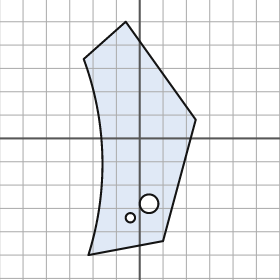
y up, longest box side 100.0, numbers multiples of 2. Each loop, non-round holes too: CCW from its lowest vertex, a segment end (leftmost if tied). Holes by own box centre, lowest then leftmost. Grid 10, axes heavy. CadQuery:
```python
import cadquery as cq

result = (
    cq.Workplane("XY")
    .moveTo(-22.0, -50.0)
    .lineTo(10.0, -44.0)
    .lineTo(24.0, 8.0)
    .lineTo(-6.0, 50.0)
    .lineTo(-24.0, 34.0)
    .threePointArc((-16.0, -8.0), (-22.0, -50.0))
    .close()
    .moveTo(-4.0, -34.0)
    .circle(2.0)
    .moveTo(4.0, -28.0)
    .circle(4.0)
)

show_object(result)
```